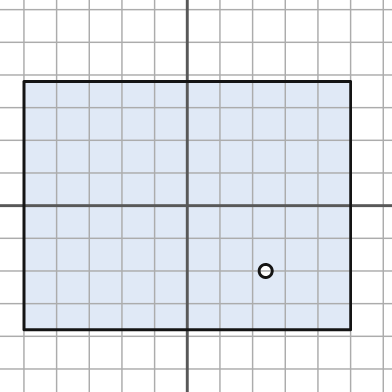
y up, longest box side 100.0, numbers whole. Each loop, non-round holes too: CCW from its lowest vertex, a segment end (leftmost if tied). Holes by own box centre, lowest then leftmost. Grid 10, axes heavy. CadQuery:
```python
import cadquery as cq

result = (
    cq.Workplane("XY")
    .moveTo(-50.0, -38.0)
    .lineTo(50.0, -38.0)
    .lineTo(50.0, 38.0)
    .lineTo(-50.0, 38.0)
    .close()
    .moveTo(24.0, -20.0)
    .circle(2.0)
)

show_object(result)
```